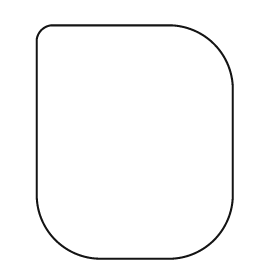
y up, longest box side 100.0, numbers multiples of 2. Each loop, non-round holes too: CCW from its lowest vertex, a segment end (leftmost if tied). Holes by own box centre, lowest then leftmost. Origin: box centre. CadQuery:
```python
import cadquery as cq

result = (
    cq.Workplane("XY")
    .moveTo(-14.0, -50.0)
    .lineTo(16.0, -50.0)
    .threePointArc((34.0, -42.0), (42.0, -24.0))
    .lineTo(42.0, 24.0)
    .threePointArc((34.0, 42.0), (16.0, 50.0))
    .lineTo(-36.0, 50.0)
    .threePointArc((-40.0, 48.0), (-42.0, 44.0))
    .lineTo(-42.0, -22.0)
    .threePointArc((-34.0, -42.0), (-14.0, -50.0))
    .close()
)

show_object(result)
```